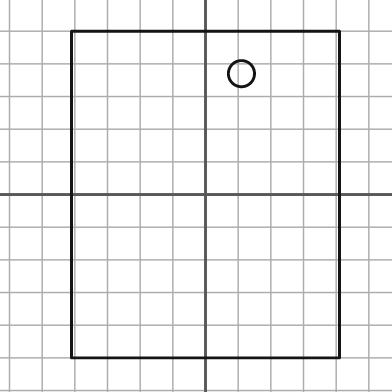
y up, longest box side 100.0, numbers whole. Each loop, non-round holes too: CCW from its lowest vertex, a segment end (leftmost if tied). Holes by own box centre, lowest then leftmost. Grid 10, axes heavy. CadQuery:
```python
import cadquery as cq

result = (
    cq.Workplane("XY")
    .moveTo(-41.0, -50.0)
    .lineTo(41.0, -50.0)
    .lineTo(41.0, 50.0)
    .lineTo(-41.0, 50.0)
    .close()
    .moveTo(11.0, 37.0)
    .circle(4.0)
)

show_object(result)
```